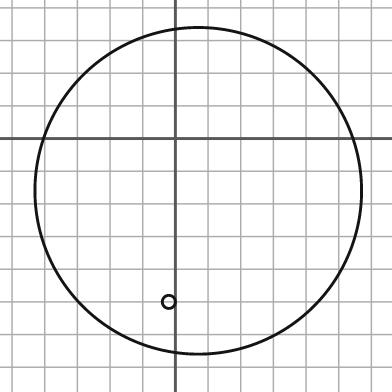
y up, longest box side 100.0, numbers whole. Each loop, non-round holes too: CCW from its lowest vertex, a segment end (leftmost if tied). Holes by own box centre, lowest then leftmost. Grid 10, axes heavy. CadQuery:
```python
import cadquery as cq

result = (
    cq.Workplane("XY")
    .moveTo(7.0, -16.0)
    .circle(50.0)
    .moveTo(-2.0, -50.0)
    .circle(2.0)
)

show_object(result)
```